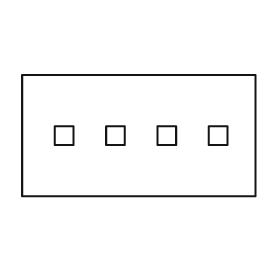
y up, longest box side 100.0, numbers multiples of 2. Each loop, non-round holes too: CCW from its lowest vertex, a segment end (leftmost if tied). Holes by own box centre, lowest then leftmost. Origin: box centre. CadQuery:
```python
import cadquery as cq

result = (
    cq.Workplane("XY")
    .moveTo(-50.0, -26.0)
    .lineTo(50.0, -26.0)
    .lineTo(50.0, 26.0)
    .lineTo(-50.0, 26.0)
    .close()
    .moveTo(-36.0, -4.0)
    .lineTo(-28.0, -4.0)
    .lineTo(-28.0, 4.0)
    .lineTo(-36.0, 4.0)
    .close()
    .moveTo(-14.0, -4.0)
    .lineTo(-6.0, -4.0)
    .lineTo(-6.0, 4.0)
    .lineTo(-14.0, 4.0)
    .close()
    .moveTo(8.0, -4.0)
    .lineTo(16.0, -4.0)
    .lineTo(16.0, 4.0)
    .lineTo(8.0, 4.0)
    .close()
    .moveTo(30.0, -4.0)
    .lineTo(38.0, -4.0)
    .lineTo(38.0, 4.0)
    .lineTo(30.0, 4.0)
    .close()
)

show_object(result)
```